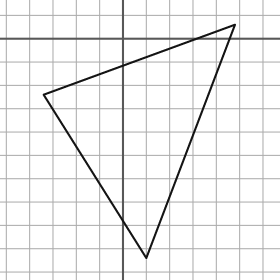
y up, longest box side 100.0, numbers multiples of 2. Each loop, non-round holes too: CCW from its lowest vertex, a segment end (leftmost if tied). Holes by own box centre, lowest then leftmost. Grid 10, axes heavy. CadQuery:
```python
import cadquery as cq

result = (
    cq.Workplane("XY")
    .moveTo(10.0, -94.0)
    .lineTo(48.0, 6.0)
    .lineTo(-34.0, -24.0)
    .close()
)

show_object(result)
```